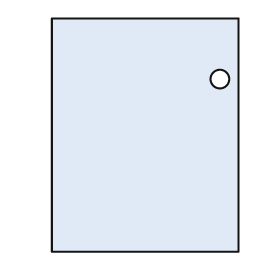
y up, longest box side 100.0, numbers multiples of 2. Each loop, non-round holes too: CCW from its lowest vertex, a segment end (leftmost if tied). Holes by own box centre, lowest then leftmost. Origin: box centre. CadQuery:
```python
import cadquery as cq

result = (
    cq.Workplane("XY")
    .moveTo(-40.0, -50.0)
    .lineTo(40.0, -50.0)
    .lineTo(40.0, 50.0)
    .lineTo(-40.0, 50.0)
    .close()
    .moveTo(32.0, 24.0)
    .circle(4.0)
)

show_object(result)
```